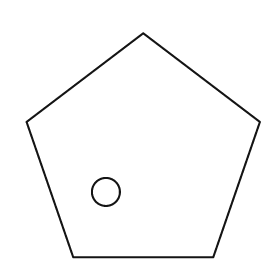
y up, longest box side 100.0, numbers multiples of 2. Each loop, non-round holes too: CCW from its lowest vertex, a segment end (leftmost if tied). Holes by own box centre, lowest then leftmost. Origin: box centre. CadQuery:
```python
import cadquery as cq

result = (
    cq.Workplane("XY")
    .moveTo(-30.0, -48.0)
    .lineTo(30.0, -48.0)
    .lineTo(50.0, 10.0)
    .lineTo(0.0, 48.0)
    .lineTo(-50.0, 10.0)
    .close()
    .moveTo(-16.0, -20.0)
    .circle(6.0)
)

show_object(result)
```